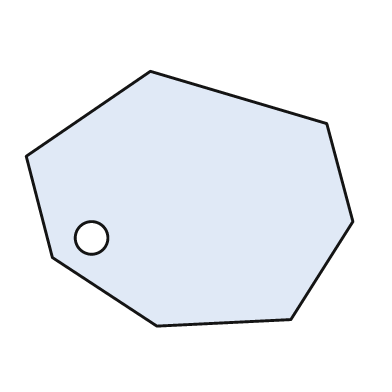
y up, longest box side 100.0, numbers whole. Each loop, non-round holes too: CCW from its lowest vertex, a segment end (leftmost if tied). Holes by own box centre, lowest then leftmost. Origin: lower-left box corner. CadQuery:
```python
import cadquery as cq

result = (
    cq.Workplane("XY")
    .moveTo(40.0, 0.0)
    .lineTo(81.0, 2.0)
    .lineTo(100.0, 32.0)
    .lineTo(92.0, 62.0)
    .lineTo(38.0, 78.0)
    .lineTo(0.0, 52.0)
    .lineTo(8.0, 21.0)
    .close()
    .moveTo(20.0, 27.0)
    .circle(5.0)
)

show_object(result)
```